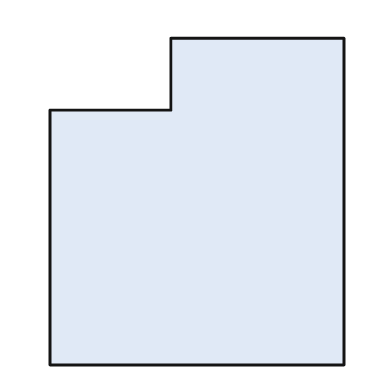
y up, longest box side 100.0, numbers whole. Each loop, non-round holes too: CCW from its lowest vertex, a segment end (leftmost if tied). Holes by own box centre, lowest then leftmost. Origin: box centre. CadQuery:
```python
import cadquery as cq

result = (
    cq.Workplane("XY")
    .moveTo(-45.0, -50.0)
    .lineTo(45.0, -50.0)
    .lineTo(45.0, 50.0)
    .lineTo(-8.0, 50.0)
    .lineTo(-8.0, 28.0)
    .lineTo(-45.0, 28.0)
    .close()
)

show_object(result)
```